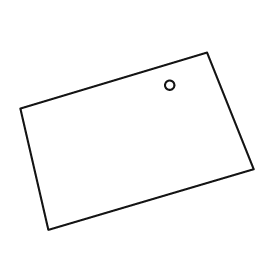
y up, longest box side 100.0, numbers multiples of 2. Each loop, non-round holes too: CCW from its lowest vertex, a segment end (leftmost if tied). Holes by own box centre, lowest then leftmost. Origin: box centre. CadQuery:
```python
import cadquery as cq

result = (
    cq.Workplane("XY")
    .moveTo(-38.0, -38.0)
    .lineTo(50.0, -12.0)
    .lineTo(30.0, 38.0)
    .lineTo(-50.0, 14.0)
    .close()
    .moveTo(14.0, 24.0)
    .circle(2.0)
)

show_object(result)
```